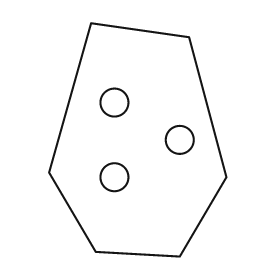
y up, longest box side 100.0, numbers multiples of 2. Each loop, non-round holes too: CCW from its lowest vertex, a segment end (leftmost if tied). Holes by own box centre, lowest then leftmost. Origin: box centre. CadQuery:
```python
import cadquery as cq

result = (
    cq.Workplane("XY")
    .moveTo(18.0, -50.0)
    .lineTo(38.0, -16.0)
    .lineTo(22.0, 44.0)
    .lineTo(-20.0, 50.0)
    .lineTo(-38.0, -14.0)
    .lineTo(-18.0, -48.0)
    .close()
    .moveTo(-10.0, -16.0)
    .circle(6.0)
    .moveTo(18.0, 0.0)
    .circle(6.0)
    .moveTo(-10.0, 16.0)
    .circle(6.0)
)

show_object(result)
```